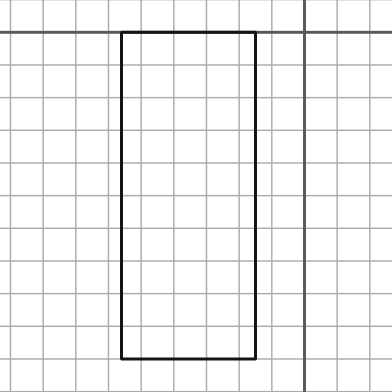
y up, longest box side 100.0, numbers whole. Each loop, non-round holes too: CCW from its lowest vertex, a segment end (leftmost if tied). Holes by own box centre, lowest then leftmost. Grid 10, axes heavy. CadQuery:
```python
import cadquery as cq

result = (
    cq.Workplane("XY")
    .moveTo(-56.0, -100.0)
    .lineTo(-15.0, -100.0)
    .lineTo(-15.0, 0.0)
    .lineTo(-56.0, 0.0)
    .close()
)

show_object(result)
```